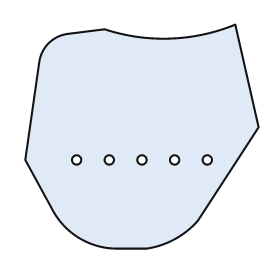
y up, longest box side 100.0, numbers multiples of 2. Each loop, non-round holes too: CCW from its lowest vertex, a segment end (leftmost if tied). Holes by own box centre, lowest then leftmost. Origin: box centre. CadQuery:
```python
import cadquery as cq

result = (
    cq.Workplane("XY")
    .moveTo(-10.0, -48.0)
    .lineTo(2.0, -48.0)
    .threePointArc((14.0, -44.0), (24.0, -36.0))
    .lineTo(50.0, 4.0)
    .lineTo(40.0, 48.0)
    .threePointArc((12.0, 42.0), (-16.0, 46.0))
    .lineTo(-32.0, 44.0)
    .threePointArc((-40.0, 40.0), (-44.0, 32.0))
    .lineTo(-50.0, -10.0)
    .lineTo(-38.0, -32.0)
    .threePointArc((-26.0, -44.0), (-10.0, -48.0))
    .close()
    .moveTo(-28.0, -10.0)
    .circle(2.0)
    .moveTo(-14.0, -10.0)
    .circle(2.0)
    .moveTo(0.0, -10.0)
    .circle(2.0)
    .moveTo(14.0, -10.0)
    .circle(2.0)
    .moveTo(28.0, -10.0)
    .circle(2.0)
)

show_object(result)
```